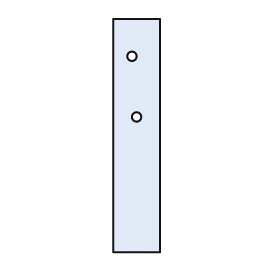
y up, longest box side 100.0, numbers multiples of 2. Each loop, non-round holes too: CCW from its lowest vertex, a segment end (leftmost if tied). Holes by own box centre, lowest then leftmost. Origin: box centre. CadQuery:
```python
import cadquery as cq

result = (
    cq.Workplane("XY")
    .moveTo(-10.0, -50.0)
    .lineTo(10.0, -50.0)
    .lineTo(10.0, 50.0)
    .lineTo(-10.0, 50.0)
    .close()
    .moveTo(0.0, 8.0)
    .circle(2.0)
    .moveTo(-2.0, 34.0)
    .circle(2.0)
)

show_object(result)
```